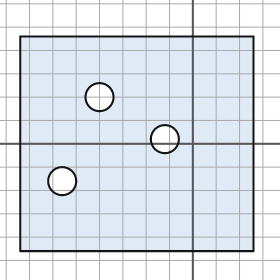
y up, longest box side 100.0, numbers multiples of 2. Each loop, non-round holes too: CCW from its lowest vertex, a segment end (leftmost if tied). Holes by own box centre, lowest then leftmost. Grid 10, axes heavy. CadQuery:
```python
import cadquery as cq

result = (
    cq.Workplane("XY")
    .moveTo(-74.0, -46.0)
    .lineTo(26.0, -46.0)
    .lineTo(26.0, 46.0)
    .lineTo(-74.0, 46.0)
    .close()
    .moveTo(-56.0, -16.0)
    .circle(6.0)
    .moveTo(-12.0, 2.0)
    .circle(6.0)
    .moveTo(-40.0, 20.0)
    .circle(6.0)
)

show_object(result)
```